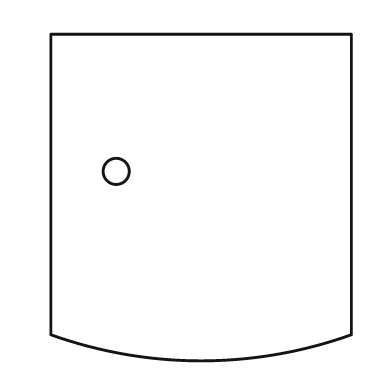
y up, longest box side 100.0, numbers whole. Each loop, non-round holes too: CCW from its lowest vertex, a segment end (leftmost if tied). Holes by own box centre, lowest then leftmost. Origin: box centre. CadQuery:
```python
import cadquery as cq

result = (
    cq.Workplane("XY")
    .moveTo(-46.0, -42.0)
    .threePointArc((0.0, -50.0), (46.0, -42.0))
    .lineTo(46.0, 50.0)
    .lineTo(-46.0, 50.0)
    .close()
    .moveTo(-26.0, 8.0)
    .circle(4.0)
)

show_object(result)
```